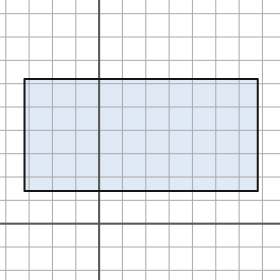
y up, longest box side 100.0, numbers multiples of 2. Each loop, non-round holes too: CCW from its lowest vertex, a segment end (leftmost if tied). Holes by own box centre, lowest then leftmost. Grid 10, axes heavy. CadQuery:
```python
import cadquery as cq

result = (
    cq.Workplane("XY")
    .moveTo(-32.0, 14.0)
    .lineTo(68.0, 14.0)
    .lineTo(68.0, 62.0)
    .lineTo(-32.0, 62.0)
    .close()
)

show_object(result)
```